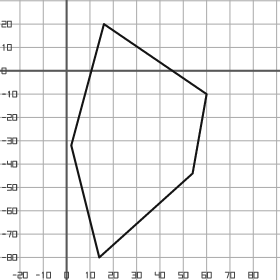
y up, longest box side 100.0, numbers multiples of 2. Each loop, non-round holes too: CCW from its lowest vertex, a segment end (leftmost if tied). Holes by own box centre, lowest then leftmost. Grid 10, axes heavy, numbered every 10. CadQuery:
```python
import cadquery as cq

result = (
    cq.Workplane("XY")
    .moveTo(14.0, -80.0)
    .lineTo(54.0, -44.0)
    .lineTo(60.0, -10.0)
    .lineTo(16.0, 20.0)
    .lineTo(2.0, -32.0)
    .close()
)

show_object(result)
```